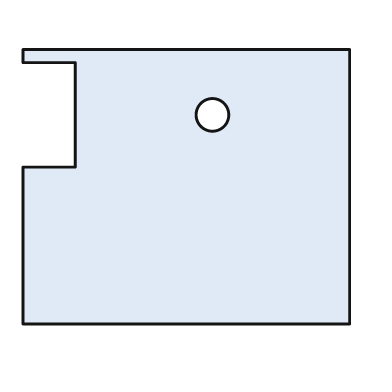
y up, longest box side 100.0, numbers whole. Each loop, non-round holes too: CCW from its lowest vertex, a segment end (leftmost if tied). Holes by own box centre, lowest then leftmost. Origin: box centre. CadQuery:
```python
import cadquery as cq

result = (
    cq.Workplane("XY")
    .moveTo(-50.0, -42.0)
    .lineTo(50.0, -42.0)
    .lineTo(50.0, 42.0)
    .lineTo(-50.0, 42.0)
    .lineTo(-50.0, 38.0)
    .lineTo(-34.0, 38.0)
    .lineTo(-34.0, 6.0)
    .lineTo(-50.0, 6.0)
    .close()
    .moveTo(8.0, 22.0)
    .circle(5.0)
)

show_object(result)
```